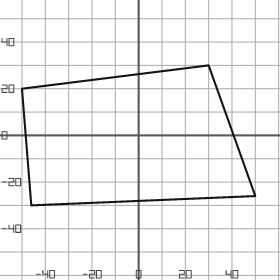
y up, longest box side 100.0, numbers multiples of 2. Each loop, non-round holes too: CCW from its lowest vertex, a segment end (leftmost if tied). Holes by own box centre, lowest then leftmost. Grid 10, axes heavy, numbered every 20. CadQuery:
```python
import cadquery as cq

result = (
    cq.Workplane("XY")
    .moveTo(-46.0, -30.0)
    .lineTo(50.0, -26.0)
    .lineTo(30.0, 30.0)
    .lineTo(-50.0, 20.0)
    .close()
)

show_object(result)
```